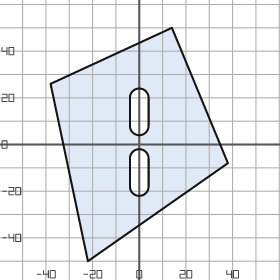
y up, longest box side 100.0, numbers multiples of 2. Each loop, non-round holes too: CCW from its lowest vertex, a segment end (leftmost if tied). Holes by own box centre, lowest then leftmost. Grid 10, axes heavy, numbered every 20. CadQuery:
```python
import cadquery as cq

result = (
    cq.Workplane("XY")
    .moveTo(-22.0, -50.0)
    .lineTo(38.0, -8.0)
    .lineTo(14.0, 50.0)
    .lineTo(-38.0, 26.0)
    .close()
    .moveTo(-4.0, -18.0)
    .threePointArc((0.0, -22.0), (4.0, -18.0))
    .lineTo(4.0, -6.0)
    .threePointArc((0.0, -2.0), (-4.0, -6.0))
    .close()
    .moveTo(-4.0, 8.0)
    .threePointArc((0.0, 4.0), (4.0, 8.0))
    .lineTo(4.0, 20.0)
    .threePointArc((0.0, 24.0), (-4.0, 20.0))
    .close()
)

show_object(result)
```